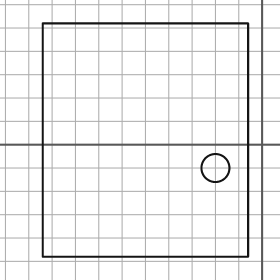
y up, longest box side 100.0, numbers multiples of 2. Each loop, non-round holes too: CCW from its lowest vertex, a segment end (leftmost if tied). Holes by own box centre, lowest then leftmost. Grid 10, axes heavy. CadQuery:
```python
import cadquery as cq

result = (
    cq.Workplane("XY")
    .moveTo(-94.0, -48.0)
    .lineTo(-6.0, -48.0)
    .lineTo(-6.0, 52.0)
    .lineTo(-94.0, 52.0)
    .close()
    .moveTo(-20.0, -10.0)
    .circle(6.0)
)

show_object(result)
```